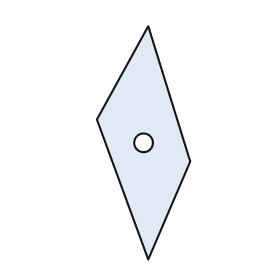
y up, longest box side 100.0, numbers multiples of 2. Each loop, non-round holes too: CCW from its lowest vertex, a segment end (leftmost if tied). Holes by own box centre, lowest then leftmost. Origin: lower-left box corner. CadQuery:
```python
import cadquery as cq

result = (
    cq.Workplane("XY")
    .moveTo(22.0, 0.0)
    .lineTo(40.0, 42.0)
    .lineTo(22.0, 100.0)
    .lineTo(0.0, 60.0)
    .close()
    .moveTo(20.0, 50.0)
    .circle(4.0)
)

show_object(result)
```